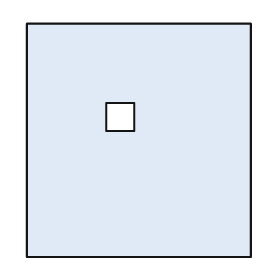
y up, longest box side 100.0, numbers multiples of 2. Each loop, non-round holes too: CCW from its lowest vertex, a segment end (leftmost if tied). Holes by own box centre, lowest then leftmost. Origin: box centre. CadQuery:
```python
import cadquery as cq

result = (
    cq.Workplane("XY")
    .moveTo(-48.0, -50.0)
    .lineTo(48.0, -50.0)
    .lineTo(48.0, 50.0)
    .lineTo(-48.0, 50.0)
    .close()
    .moveTo(-14.0, 4.0)
    .lineTo(-2.0, 4.0)
    .lineTo(-2.0, 16.0)
    .lineTo(-14.0, 16.0)
    .close()
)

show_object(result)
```